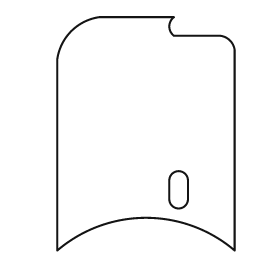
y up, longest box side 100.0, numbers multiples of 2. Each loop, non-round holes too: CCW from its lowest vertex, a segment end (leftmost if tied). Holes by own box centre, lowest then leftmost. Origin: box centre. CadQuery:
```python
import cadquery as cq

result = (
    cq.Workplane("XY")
    .moveTo(-38.0, -50.0)
    .threePointArc((0.0, -36.0), (38.0, -50.0))
    .lineTo(38.0, 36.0)
    .threePointArc((36.0, 40.0), (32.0, 42.0))
    .lineTo(12.0, 42.0)
    .threePointArc((10.0, 46.0), (12.0, 50.0))
    .lineTo(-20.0, 50.0)
    .threePointArc((-32.0, 44.0), (-38.0, 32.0))
    .close()
    .moveTo(10.0, -28.0)
    .threePointArc((14.0, -32.0), (18.0, -28.0))
    .lineTo(18.0, -20.0)
    .threePointArc((14.0, -16.0), (10.0, -20.0))
    .close()
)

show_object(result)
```